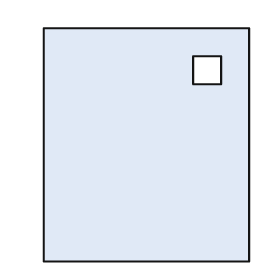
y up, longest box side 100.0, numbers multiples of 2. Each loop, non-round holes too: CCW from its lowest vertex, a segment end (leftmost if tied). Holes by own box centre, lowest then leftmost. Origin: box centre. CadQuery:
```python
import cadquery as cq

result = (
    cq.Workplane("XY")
    .moveTo(-44.0, -50.0)
    .lineTo(44.0, -50.0)
    .lineTo(44.0, 50.0)
    .lineTo(-44.0, 50.0)
    .close()
    .moveTo(20.0, 26.0)
    .lineTo(32.0, 26.0)
    .lineTo(32.0, 38.0)
    .lineTo(20.0, 38.0)
    .close()
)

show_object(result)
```